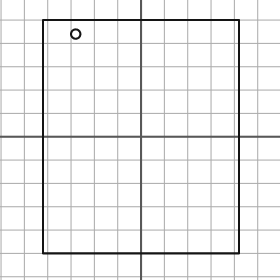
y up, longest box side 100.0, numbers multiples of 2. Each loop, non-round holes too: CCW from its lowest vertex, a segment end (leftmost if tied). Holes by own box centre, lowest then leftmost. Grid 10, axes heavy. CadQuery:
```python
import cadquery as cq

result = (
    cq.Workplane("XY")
    .moveTo(-42.0, -50.0)
    .lineTo(42.0, -50.0)
    .lineTo(42.0, 50.0)
    .lineTo(-42.0, 50.0)
    .close()
    .moveTo(-28.0, 44.0)
    .circle(2.0)
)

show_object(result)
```